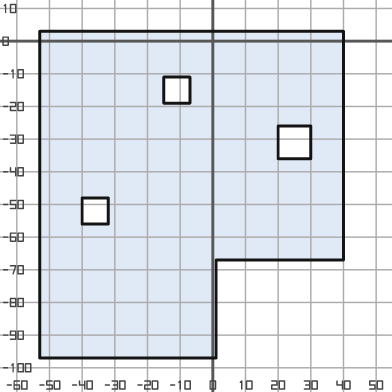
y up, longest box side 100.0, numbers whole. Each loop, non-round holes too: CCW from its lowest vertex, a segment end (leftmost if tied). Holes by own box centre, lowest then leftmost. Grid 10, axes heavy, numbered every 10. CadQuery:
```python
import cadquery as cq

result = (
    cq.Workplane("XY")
    .moveTo(-53.0, -97.0)
    .lineTo(1.0, -97.0)
    .lineTo(1.0, -67.0)
    .lineTo(40.0, -67.0)
    .lineTo(40.0, 3.0)
    .lineTo(-53.0, 3.0)
    .close()
    .moveTo(-40.0, -56.0)
    .lineTo(-32.0, -56.0)
    .lineTo(-32.0, -48.0)
    .lineTo(-40.0, -48.0)
    .close()
    .moveTo(20.0, -36.0)
    .lineTo(30.0, -36.0)
    .lineTo(30.0, -26.0)
    .lineTo(20.0, -26.0)
    .close()
    .moveTo(-15.0, -19.0)
    .lineTo(-7.0, -19.0)
    .lineTo(-7.0, -11.0)
    .lineTo(-15.0, -11.0)
    .close()
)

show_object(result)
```